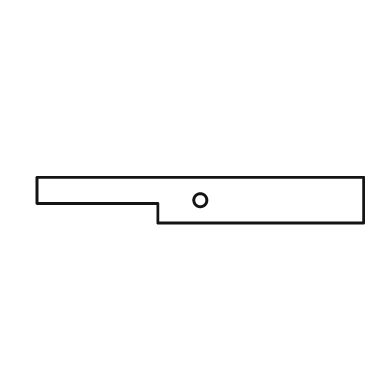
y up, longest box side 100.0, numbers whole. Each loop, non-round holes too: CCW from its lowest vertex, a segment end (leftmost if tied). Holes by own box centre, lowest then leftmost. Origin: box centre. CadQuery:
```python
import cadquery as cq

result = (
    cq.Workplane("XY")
    .moveTo(-13.0, -7.0)
    .lineTo(50.0, -7.0)
    .lineTo(50.0, 7.0)
    .lineTo(-50.0, 7.0)
    .lineTo(-50.0, -1.0)
    .lineTo(-13.0, -1.0)
    .close()
    .moveTo(0.0, 0.0)
    .circle(2.0)
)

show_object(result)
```